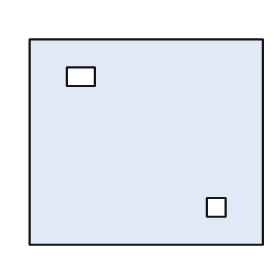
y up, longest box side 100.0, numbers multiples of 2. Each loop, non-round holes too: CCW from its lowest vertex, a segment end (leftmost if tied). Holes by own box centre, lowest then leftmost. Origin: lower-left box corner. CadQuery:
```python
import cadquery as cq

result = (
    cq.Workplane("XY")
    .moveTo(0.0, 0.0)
    .lineTo(100.0, 0.0)
    .lineTo(100.0, 88.0)
    .lineTo(0.0, 88.0)
    .close()
    .moveTo(76.0, 12.0)
    .lineTo(84.0, 12.0)
    .lineTo(84.0, 20.0)
    .lineTo(76.0, 20.0)
    .close()
    .moveTo(16.0, 68.0)
    .lineTo(28.0, 68.0)
    .lineTo(28.0, 76.0)
    .lineTo(16.0, 76.0)
    .close()
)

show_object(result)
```